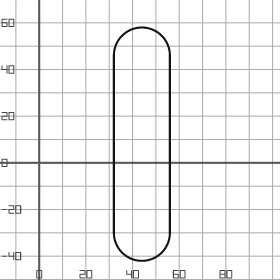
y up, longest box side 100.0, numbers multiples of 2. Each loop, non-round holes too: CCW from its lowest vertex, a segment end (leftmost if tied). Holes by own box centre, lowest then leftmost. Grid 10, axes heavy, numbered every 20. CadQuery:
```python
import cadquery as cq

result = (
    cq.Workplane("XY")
    .moveTo(32.0, -30.0)
    .threePointArc((44.0, -42.0), (56.0, -30.0))
    .lineTo(56.0, 46.0)
    .threePointArc((44.0, 58.0), (32.0, 46.0))
    .close()
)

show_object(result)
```